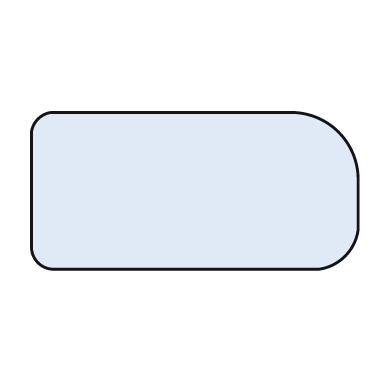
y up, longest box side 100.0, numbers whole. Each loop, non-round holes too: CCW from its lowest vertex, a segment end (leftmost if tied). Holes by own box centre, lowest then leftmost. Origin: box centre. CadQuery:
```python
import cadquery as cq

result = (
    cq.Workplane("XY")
    .moveTo(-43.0, -24.0)
    .lineTo(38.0, -24.0)
    .threePointArc((46.0, -20.0), (50.0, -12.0))
    .lineTo(50.0, 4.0)
    .threePointArc((44.0, 18.0), (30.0, 24.0))
    .lineTo(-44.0, 24.0)
    .threePointArc((-48.0, 22.0), (-50.0, 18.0))
    .lineTo(-50.0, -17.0)
    .threePointArc((-48.0, -22.0), (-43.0, -24.0))
    .close()
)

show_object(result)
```